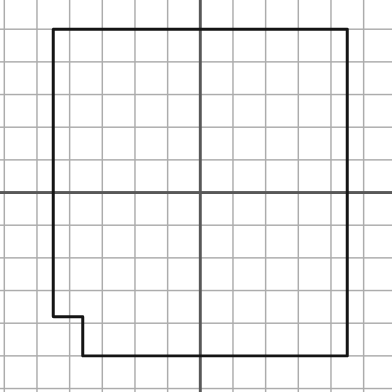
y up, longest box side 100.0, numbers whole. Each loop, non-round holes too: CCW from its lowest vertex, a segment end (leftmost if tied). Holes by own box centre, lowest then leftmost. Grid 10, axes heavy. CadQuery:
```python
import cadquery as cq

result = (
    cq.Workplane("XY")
    .moveTo(-36.0, -50.0)
    .lineTo(45.0, -50.0)
    .lineTo(45.0, 50.0)
    .lineTo(-45.0, 50.0)
    .lineTo(-45.0, -38.0)
    .lineTo(-36.0, -38.0)
    .close()
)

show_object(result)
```